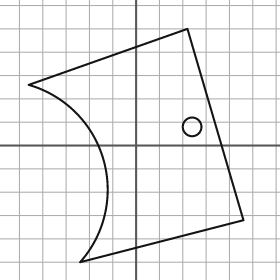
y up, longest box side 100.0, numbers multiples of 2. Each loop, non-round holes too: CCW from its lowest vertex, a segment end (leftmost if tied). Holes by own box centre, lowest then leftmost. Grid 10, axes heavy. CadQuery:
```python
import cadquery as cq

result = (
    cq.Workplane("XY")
    .moveTo(-24.0, -50.0)
    .lineTo(46.0, -32.0)
    .lineTo(22.0, 50.0)
    .lineTo(-46.0, 26.0)
    .threePointArc((-14.0, -6.0), (-24.0, -50.0))
    .close()
    .moveTo(24.0, 8.0)
    .circle(4.0)
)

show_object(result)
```